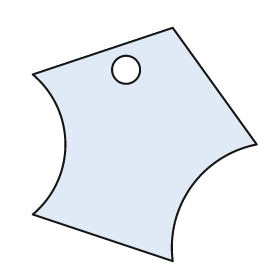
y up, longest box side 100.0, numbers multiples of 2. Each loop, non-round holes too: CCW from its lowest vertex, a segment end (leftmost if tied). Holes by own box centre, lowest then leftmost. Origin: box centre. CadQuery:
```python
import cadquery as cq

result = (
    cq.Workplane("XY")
    .moveTo(12.0, -50.0)
    .threePointArc((20.0, -18.0), (48.0, 0.0))
    .lineTo(12.0, 50.0)
    .lineTo(-48.0, 30.0)
    .threePointArc((-34.0, 0.0), (-48.0, -30.0))
    .close()
    .moveTo(-8.0, 32.0)
    .circle(6.0)
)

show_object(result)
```